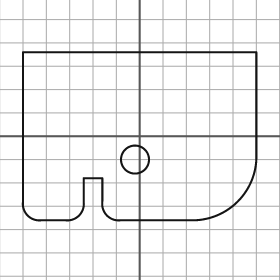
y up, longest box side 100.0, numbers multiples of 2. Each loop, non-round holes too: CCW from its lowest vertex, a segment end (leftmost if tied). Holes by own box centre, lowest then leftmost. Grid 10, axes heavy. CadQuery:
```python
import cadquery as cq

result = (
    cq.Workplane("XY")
    .moveTo(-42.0, -36.0)
    .lineTo(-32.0, -36.0)
    .threePointArc((-26.0, -34.0), (-24.0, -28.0))
    .lineTo(-24.0, -18.0)
    .lineTo(-16.0, -18.0)
    .lineTo(-16.0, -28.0)
    .threePointArc((-14.0, -34.0), (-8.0, -36.0))
    .lineTo(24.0, -36.0)
    .threePointArc((42.0, -28.0), (50.0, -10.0))
    .lineTo(50.0, 36.0)
    .lineTo(-50.0, 36.0)
    .lineTo(-50.0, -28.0)
    .threePointArc((-48.0, -34.0), (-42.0, -36.0))
    .close()
    .moveTo(-2.0, -10.0)
    .circle(6.0)
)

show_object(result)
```